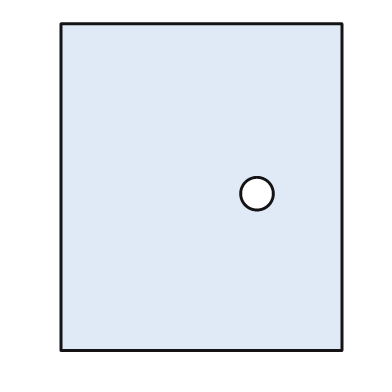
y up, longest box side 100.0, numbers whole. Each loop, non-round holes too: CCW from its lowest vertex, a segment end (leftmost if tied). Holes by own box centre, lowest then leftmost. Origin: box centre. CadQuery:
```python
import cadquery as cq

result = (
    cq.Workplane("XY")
    .moveTo(-43.0, -50.0)
    .lineTo(43.0, -50.0)
    .lineTo(43.0, 50.0)
    .lineTo(-43.0, 50.0)
    .close()
    .moveTo(17.0, -2.0)
    .circle(5.0)
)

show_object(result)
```